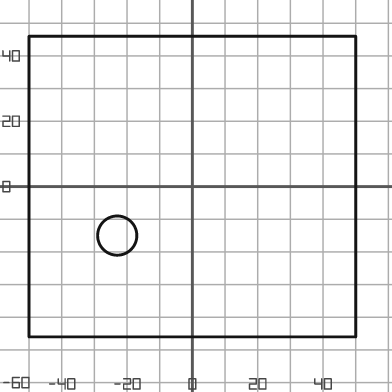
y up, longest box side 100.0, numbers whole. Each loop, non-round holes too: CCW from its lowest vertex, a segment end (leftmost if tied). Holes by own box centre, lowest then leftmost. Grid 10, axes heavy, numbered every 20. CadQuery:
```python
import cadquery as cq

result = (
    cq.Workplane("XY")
    .moveTo(-50.0, -46.0)
    .lineTo(50.0, -46.0)
    .lineTo(50.0, 46.0)
    .lineTo(-50.0, 46.0)
    .close()
    .moveTo(-23.0, -15.0)
    .circle(6.0)
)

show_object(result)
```